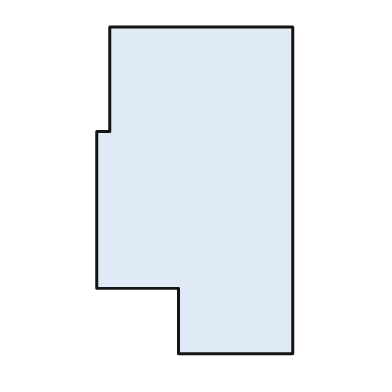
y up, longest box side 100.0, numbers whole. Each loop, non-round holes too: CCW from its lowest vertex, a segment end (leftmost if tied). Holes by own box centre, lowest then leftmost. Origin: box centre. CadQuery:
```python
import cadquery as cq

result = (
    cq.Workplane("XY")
    .moveTo(-5.0, -50.0)
    .lineTo(30.0, -50.0)
    .lineTo(30.0, 50.0)
    .lineTo(-26.0, 50.0)
    .lineTo(-26.0, 18.0)
    .lineTo(-30.0, 18.0)
    .lineTo(-30.0, -30.0)
    .lineTo(-5.0, -30.0)
    .close()
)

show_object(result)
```